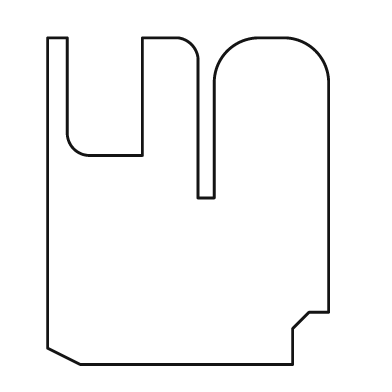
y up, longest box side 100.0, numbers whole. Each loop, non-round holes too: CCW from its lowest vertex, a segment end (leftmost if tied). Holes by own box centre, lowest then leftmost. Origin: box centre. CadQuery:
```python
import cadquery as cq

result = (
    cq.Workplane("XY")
    .moveTo(-33.0, -50.0)
    .lineTo(32.0, -50.0)
    .lineTo(32.0, -39.0)
    .lineTo(37.0, -34.0)
    .lineTo(43.0, -34.0)
    .lineTo(43.0, 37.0)
    .threePointArc((39.0, 46.0), (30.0, 50.0))
    .lineTo(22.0, 50.0)
    .threePointArc((12.0, 46.0), (8.0, 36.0))
    .lineTo(8.0, 1.0)
    .lineTo(3.0, 1.0)
    .lineTo(3.0, 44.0)
    .threePointArc((1.0, 48.0), (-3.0, 50.0))
    .lineTo(-14.0, 50.0)
    .lineTo(-14.0, 14.0)
    .lineTo(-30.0, 14.0)
    .threePointArc((-35.0, 16.0), (-37.0, 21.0))
    .lineTo(-37.0, 50.0)
    .lineTo(-43.0, 50.0)
    .lineTo(-43.0, -45.0)
    .close()
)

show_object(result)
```